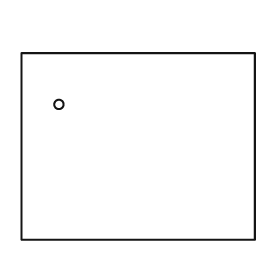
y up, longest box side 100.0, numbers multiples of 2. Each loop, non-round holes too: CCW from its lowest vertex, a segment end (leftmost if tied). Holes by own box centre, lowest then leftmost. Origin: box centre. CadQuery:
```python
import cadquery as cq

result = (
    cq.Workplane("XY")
    .moveTo(-50.0, -40.0)
    .lineTo(50.0, -40.0)
    .lineTo(50.0, 40.0)
    .lineTo(-50.0, 40.0)
    .close()
    .moveTo(-34.0, 18.0)
    .circle(2.0)
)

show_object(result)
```